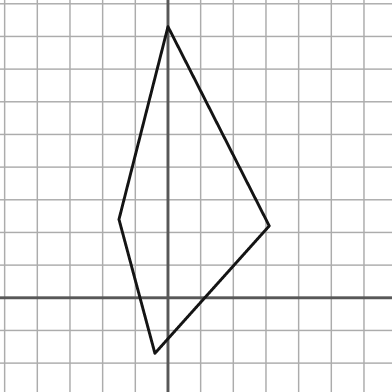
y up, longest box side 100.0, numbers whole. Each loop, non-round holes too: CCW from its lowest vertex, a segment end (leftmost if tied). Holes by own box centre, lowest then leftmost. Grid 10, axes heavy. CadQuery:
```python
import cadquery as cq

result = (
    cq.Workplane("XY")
    .moveTo(-4.0, -17.0)
    .lineTo(31.0, 22.0)
    .lineTo(0.0, 83.0)
    .lineTo(-15.0, 24.0)
    .close()
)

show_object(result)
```